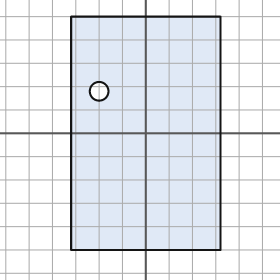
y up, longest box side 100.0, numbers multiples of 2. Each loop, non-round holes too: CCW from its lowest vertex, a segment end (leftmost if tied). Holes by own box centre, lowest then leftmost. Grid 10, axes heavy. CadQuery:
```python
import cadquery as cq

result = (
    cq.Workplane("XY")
    .moveTo(-32.0, -50.0)
    .lineTo(32.0, -50.0)
    .lineTo(32.0, 50.0)
    .lineTo(-32.0, 50.0)
    .close()
    .moveTo(-20.0, 18.0)
    .circle(4.0)
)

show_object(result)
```